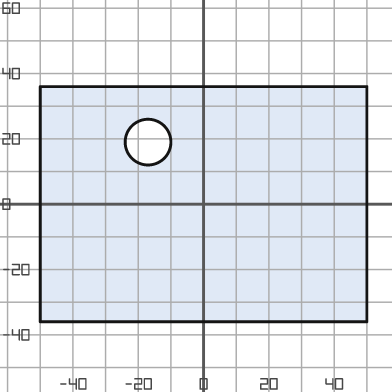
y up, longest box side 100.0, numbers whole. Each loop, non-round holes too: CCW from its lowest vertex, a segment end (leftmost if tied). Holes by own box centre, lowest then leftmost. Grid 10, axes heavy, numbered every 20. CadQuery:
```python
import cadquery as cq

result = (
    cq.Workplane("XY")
    .moveTo(-50.0, -36.0)
    .lineTo(50.0, -36.0)
    .lineTo(50.0, 36.0)
    .lineTo(-50.0, 36.0)
    .close()
    .moveTo(-17.0, 19.0)
    .circle(7.0)
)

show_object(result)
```